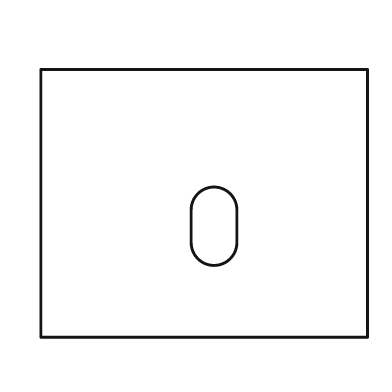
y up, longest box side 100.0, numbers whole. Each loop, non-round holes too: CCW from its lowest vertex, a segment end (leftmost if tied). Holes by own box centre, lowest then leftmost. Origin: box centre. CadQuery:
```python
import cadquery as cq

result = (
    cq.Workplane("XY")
    .moveTo(-50.0, -41.0)
    .lineTo(50.0, -41.0)
    .lineTo(50.0, 41.0)
    .lineTo(-50.0, 41.0)
    .close()
    .moveTo(-4.0, -12.0)
    .threePointArc((3.0, -19.0), (10.0, -12.0))
    .lineTo(10.0, -2.0)
    .threePointArc((3.0, 5.0), (-4.0, -2.0))
    .close()
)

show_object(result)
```